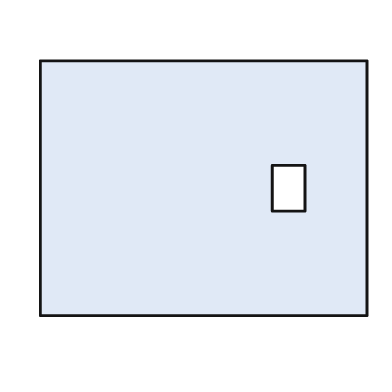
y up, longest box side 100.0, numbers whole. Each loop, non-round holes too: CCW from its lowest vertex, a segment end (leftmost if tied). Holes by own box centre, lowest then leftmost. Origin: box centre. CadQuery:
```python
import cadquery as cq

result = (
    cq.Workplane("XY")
    .moveTo(-50.0, -39.0)
    .lineTo(50.0, -39.0)
    .lineTo(50.0, 39.0)
    .lineTo(-50.0, 39.0)
    .close()
    .moveTo(21.0, -7.0)
    .lineTo(31.0, -7.0)
    .lineTo(31.0, 7.0)
    .lineTo(21.0, 7.0)
    .close()
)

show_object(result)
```